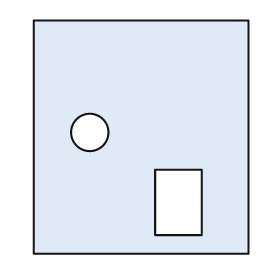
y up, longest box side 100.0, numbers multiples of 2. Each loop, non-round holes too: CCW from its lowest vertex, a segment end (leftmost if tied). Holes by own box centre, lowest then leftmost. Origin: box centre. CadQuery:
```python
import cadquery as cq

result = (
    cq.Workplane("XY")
    .moveTo(-46.0, -50.0)
    .lineTo(46.0, -50.0)
    .lineTo(46.0, 50.0)
    .lineTo(-46.0, 50.0)
    .close()
    .moveTo(6.0, -42.0)
    .lineTo(26.0, -42.0)
    .lineTo(26.0, -14.0)
    .lineTo(6.0, -14.0)
    .close()
    .moveTo(-22.0, 2.0)
    .circle(8.0)
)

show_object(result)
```